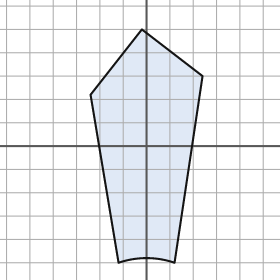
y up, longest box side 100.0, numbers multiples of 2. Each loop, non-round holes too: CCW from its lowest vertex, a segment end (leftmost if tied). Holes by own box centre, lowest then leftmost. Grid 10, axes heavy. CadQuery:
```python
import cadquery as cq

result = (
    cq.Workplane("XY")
    .moveTo(-12.0, -50.0)
    .threePointArc((0.0, -48.0), (12.0, -50.0))
    .lineTo(24.0, 30.0)
    .lineTo(-2.0, 50.0)
    .lineTo(-24.0, 22.0)
    .close()
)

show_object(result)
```